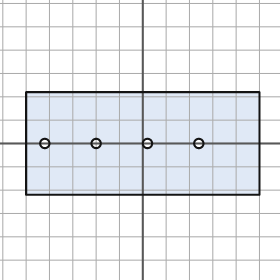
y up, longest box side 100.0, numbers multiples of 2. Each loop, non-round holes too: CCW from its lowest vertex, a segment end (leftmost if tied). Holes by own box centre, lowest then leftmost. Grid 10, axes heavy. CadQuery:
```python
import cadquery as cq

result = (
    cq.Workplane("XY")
    .moveTo(-50.0, -22.0)
    .lineTo(50.0, -22.0)
    .lineTo(50.0, 22.0)
    .lineTo(-50.0, 22.0)
    .close()
    .moveTo(-42.0, 0.0)
    .circle(2.0)
    .moveTo(-20.0, 0.0)
    .circle(2.0)
    .moveTo(2.0, 0.0)
    .circle(2.0)
    .moveTo(24.0, 0.0)
    .circle(2.0)
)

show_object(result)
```